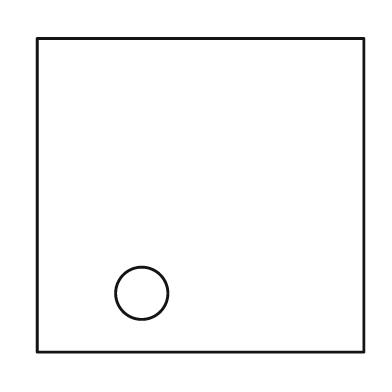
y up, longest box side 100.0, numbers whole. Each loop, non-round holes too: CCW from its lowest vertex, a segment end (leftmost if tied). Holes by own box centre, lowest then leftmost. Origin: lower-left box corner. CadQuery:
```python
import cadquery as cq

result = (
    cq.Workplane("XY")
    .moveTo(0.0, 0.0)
    .lineTo(100.0, 0.0)
    .lineTo(100.0, 96.0)
    .lineTo(0.0, 96.0)
    .close()
    .moveTo(32.0, 18.0)
    .circle(8.0)
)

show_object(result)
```